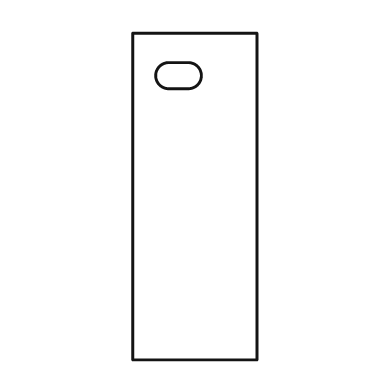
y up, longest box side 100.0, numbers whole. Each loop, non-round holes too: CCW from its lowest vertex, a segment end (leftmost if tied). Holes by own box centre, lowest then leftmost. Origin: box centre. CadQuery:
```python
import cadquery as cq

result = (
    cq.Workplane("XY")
    .moveTo(-19.0, -50.0)
    .lineTo(19.0, -50.0)
    .lineTo(19.0, 50.0)
    .lineTo(-19.0, 50.0)
    .close()
    .moveTo(-8.0, 33.0)
    .lineTo(-2.0, 33.0)
    .threePointArc((2.0, 37.0), (-2.0, 41.0))
    .lineTo(-8.0, 41.0)
    .threePointArc((-12.0, 37.0), (-8.0, 33.0))
    .close()
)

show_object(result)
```